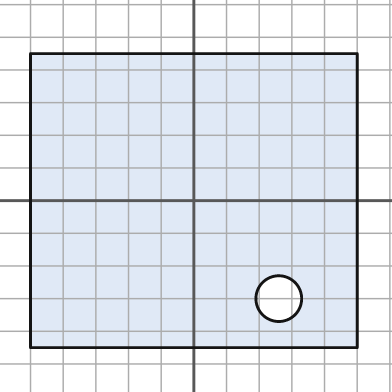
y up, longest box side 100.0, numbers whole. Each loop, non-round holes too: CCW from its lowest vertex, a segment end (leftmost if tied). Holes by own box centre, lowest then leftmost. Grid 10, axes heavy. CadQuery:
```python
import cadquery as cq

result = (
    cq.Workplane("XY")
    .moveTo(-50.0, -45.0)
    .lineTo(50.0, -45.0)
    .lineTo(50.0, 45.0)
    .lineTo(-50.0, 45.0)
    .close()
    .moveTo(26.0, -30.0)
    .circle(7.0)
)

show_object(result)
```